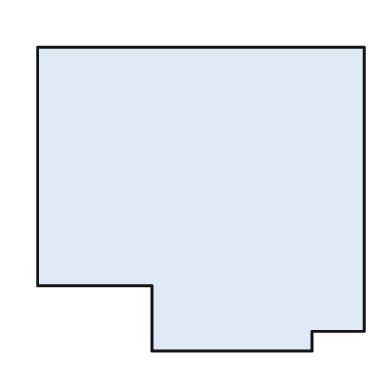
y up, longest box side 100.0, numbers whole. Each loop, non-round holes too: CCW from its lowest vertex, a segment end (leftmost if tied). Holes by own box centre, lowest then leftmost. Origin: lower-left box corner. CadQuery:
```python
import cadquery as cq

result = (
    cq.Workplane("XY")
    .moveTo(35.0, 0.0)
    .lineTo(84.0, 0.0)
    .lineTo(84.0, 6.0)
    .lineTo(100.0, 6.0)
    .lineTo(100.0, 93.0)
    .lineTo(0.0, 93.0)
    .lineTo(0.0, 20.0)
    .lineTo(35.0, 20.0)
    .close()
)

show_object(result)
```